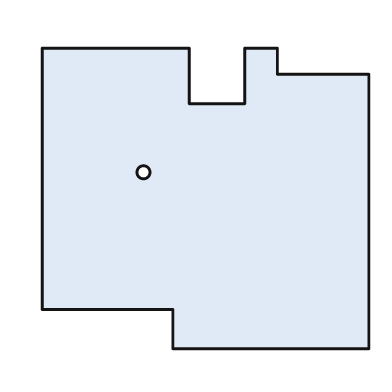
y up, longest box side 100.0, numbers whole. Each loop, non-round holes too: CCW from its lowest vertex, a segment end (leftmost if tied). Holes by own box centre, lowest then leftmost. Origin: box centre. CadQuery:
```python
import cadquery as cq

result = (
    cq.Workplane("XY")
    .moveTo(-10.0, -46.0)
    .lineTo(50.0, -46.0)
    .lineTo(50.0, 38.0)
    .lineTo(22.0, 38.0)
    .lineTo(22.0, 46.0)
    .lineTo(12.0, 46.0)
    .lineTo(12.0, 29.0)
    .lineTo(-5.0, 29.0)
    .lineTo(-5.0, 46.0)
    .lineTo(-50.0, 46.0)
    .lineTo(-50.0, -34.0)
    .lineTo(-10.0, -34.0)
    .close()
    .moveTo(-19.0, 8.0)
    .circle(2.0)
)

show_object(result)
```